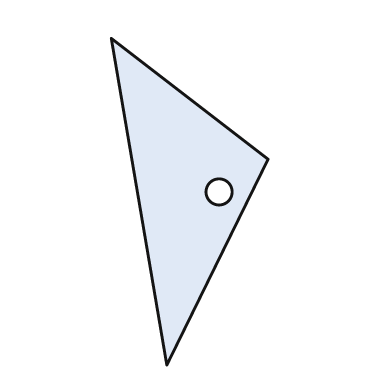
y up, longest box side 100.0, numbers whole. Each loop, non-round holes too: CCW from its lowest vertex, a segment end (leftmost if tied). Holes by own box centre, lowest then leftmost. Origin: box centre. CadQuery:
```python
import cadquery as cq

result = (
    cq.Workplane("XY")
    .moveTo(-7.0, -50.0)
    .lineTo(24.0, 13.0)
    .lineTo(-24.0, 50.0)
    .close()
    .moveTo(9.0, 3.0)
    .circle(4.0)
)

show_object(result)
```